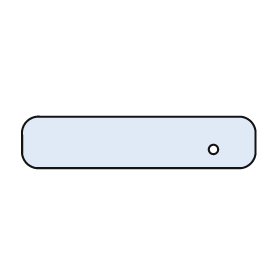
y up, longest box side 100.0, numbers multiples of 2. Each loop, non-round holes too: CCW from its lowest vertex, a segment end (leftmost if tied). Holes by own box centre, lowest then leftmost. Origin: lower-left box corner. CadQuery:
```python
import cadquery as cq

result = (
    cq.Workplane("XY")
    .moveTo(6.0, 0.0)
    .lineTo(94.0, 0.0)
    .threePointArc((98.0, 2.0), (100.0, 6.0))
    .lineTo(100.0, 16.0)
    .threePointArc((98.0, 20.0), (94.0, 22.0))
    .lineTo(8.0, 22.0)
    .threePointArc((2.0, 20.0), (0.0, 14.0))
    .lineTo(0.0, 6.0)
    .threePointArc((2.0, 2.0), (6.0, 0.0))
    .close()
    .moveTo(82.0, 8.0)
    .circle(2.0)
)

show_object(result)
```